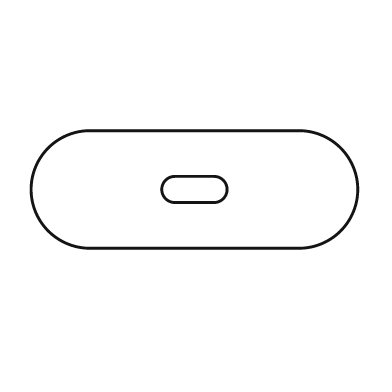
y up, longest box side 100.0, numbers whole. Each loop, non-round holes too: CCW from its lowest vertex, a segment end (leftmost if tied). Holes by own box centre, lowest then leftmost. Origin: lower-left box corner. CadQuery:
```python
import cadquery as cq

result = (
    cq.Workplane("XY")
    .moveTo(18.0, 0.0)
    .lineTo(82.0, 0.0)
    .threePointArc((100.0, 18.0), (82.0, 36.0))
    .lineTo(18.0, 36.0)
    .threePointArc((0.0, 18.0), (18.0, 0.0))
    .close()
    .moveTo(44.0, 14.0)
    .lineTo(56.0, 14.0)
    .threePointArc((60.0, 18.0), (56.0, 22.0))
    .lineTo(44.0, 22.0)
    .threePointArc((40.0, 18.0), (44.0, 14.0))
    .close()
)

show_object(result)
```